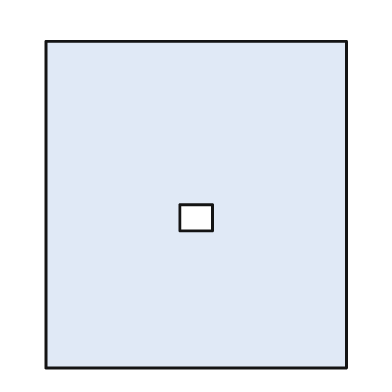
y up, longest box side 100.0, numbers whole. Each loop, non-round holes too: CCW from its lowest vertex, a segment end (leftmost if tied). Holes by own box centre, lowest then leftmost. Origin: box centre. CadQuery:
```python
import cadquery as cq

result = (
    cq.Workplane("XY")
    .moveTo(-46.0, -50.0)
    .lineTo(46.0, -50.0)
    .lineTo(46.0, 50.0)
    .lineTo(-46.0, 50.0)
    .close()
    .moveTo(-5.0, -8.0)
    .lineTo(5.0, -8.0)
    .lineTo(5.0, 0.0)
    .lineTo(-5.0, 0.0)
    .close()
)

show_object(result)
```